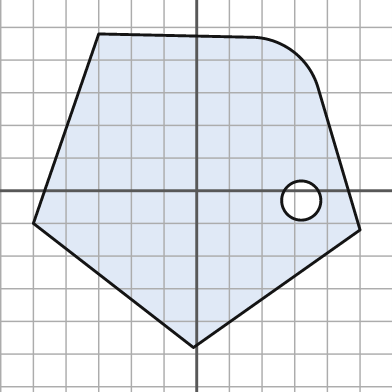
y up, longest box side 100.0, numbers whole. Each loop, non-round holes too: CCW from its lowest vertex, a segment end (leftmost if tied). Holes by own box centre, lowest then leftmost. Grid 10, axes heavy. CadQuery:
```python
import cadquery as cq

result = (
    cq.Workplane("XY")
    .moveTo(-1.0, -48.0)
    .lineTo(50.0, -12.0)
    .lineTo(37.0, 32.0)
    .threePointArc((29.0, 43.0), (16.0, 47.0))
    .lineTo(-30.0, 48.0)
    .lineTo(-50.0, -10.0)
    .close()
    .moveTo(32.0, -3.0)
    .circle(6.0)
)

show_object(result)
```